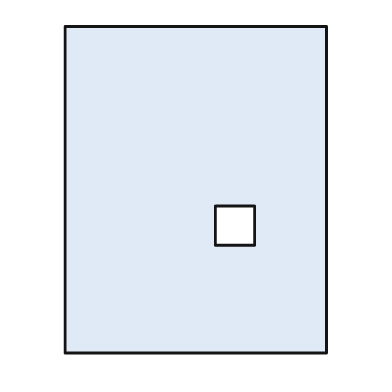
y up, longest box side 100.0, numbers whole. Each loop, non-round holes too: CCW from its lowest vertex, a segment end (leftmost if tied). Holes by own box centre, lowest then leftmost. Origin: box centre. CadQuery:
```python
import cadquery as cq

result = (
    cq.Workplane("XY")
    .moveTo(-40.0, -50.0)
    .lineTo(40.0, -50.0)
    .lineTo(40.0, 50.0)
    .lineTo(-40.0, 50.0)
    .close()
    .moveTo(6.0, -17.0)
    .lineTo(18.0, -17.0)
    .lineTo(18.0, -5.0)
    .lineTo(6.0, -5.0)
    .close()
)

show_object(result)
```